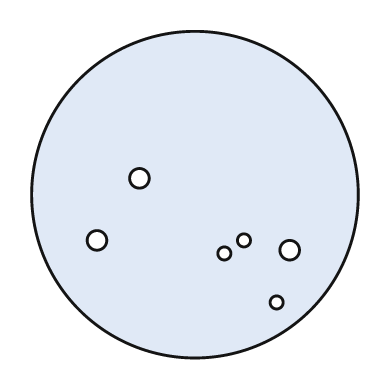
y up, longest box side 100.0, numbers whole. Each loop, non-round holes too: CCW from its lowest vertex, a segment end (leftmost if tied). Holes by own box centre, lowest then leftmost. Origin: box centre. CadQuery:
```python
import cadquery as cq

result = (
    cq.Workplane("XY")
    .moveTo(0.0, 0.0)
    .circle(50.0)
    .moveTo(25.0, -33.0)
    .circle(2.0)
    .moveTo(9.0, -18.0)
    .circle(2.0)
    .moveTo(29.0, -17.0)
    .circle(3.0)
    .moveTo(-30.0, -14.0)
    .circle(3.0)
    .moveTo(15.0, -14.0)
    .circle(2.0)
    .moveTo(-17.0, 5.0)
    .circle(3.0)
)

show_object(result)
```